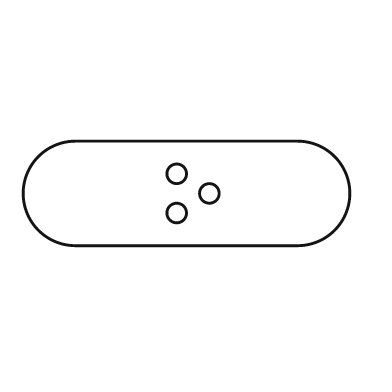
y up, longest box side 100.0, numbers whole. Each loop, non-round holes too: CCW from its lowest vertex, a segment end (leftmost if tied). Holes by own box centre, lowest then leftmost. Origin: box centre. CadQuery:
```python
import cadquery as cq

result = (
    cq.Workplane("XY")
    .moveTo(-34.0, -16.0)
    .lineTo(34.0, -16.0)
    .threePointArc((50.0, 0.0), (34.0, 16.0))
    .lineTo(-34.0, 16.0)
    .threePointArc((-50.0, 0.0), (-34.0, -16.0))
    .close()
    .moveTo(-3.0, -6.0)
    .circle(3.0)
    .moveTo(7.0, 0.0)
    .circle(3.0)
    .moveTo(-3.0, 6.0)
    .circle(3.0)
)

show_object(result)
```